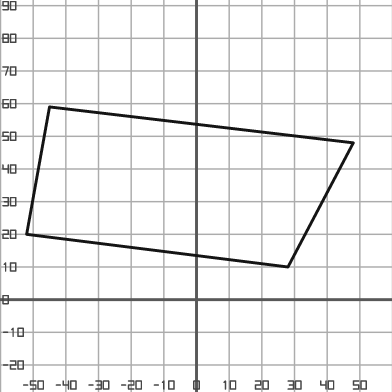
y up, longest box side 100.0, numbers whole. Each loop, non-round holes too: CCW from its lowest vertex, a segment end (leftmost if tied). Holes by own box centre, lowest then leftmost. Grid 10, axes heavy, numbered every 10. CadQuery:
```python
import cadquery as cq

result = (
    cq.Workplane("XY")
    .moveTo(28.0, 10.0)
    .lineTo(48.0, 48.0)
    .lineTo(-45.0, 59.0)
    .lineTo(-52.0, 20.0)
    .close()
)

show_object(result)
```